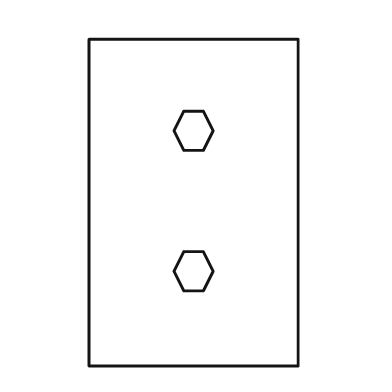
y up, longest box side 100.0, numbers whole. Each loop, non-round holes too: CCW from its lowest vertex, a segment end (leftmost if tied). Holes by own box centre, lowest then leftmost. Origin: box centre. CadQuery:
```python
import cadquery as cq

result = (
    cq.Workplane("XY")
    .moveTo(-32.0, -50.0)
    .lineTo(32.0, -50.0)
    .lineTo(32.0, 50.0)
    .lineTo(-32.0, 50.0)
    .close()
    .moveTo(-3.0, -27.0)
    .lineTo(3.0, -27.0)
    .lineTo(6.0, -21.0)
    .lineTo(3.0, -15.0)
    .lineTo(-3.0, -15.0)
    .lineTo(-6.0, -21.0)
    .close()
    .moveTo(-3.0, 16.0)
    .lineTo(3.0, 16.0)
    .lineTo(6.0, 22.0)
    .lineTo(3.0, 28.0)
    .lineTo(-3.0, 28.0)
    .lineTo(-6.0, 22.0)
    .close()
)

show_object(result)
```